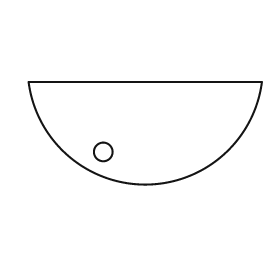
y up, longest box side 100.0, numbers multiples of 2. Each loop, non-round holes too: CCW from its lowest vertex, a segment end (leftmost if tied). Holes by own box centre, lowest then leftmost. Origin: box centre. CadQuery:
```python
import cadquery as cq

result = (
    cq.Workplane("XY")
    .moveTo(-50.0, 22.0)
    .threePointArc((0.0, -22.0), (50.0, 22.0))
    .close()
    .moveTo(-18.0, -8.0)
    .circle(4.0)
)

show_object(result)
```